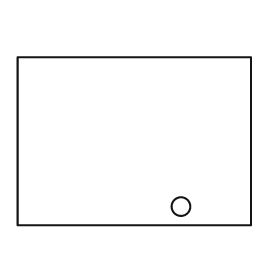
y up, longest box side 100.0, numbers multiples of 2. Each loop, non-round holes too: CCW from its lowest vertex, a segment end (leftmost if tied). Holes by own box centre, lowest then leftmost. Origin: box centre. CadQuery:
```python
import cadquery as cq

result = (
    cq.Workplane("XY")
    .moveTo(-50.0, -36.0)
    .lineTo(50.0, -36.0)
    .lineTo(50.0, 36.0)
    .lineTo(-50.0, 36.0)
    .close()
    .moveTo(20.0, -28.0)
    .circle(4.0)
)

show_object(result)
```